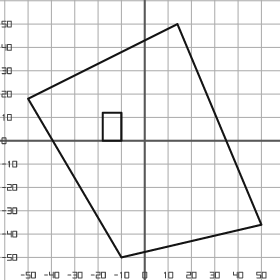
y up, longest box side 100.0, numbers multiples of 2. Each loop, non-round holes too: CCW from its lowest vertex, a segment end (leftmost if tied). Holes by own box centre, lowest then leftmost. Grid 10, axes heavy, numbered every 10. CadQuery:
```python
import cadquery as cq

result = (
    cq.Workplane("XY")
    .moveTo(-10.0, -50.0)
    .lineTo(50.0, -36.0)
    .lineTo(14.0, 50.0)
    .lineTo(-50.0, 18.0)
    .close()
    .moveTo(-18.0, 0.0)
    .lineTo(-10.0, 0.0)
    .lineTo(-10.0, 12.0)
    .lineTo(-18.0, 12.0)
    .close()
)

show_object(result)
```